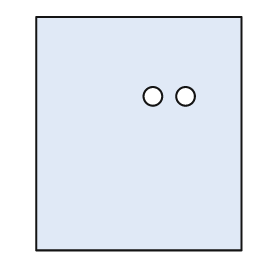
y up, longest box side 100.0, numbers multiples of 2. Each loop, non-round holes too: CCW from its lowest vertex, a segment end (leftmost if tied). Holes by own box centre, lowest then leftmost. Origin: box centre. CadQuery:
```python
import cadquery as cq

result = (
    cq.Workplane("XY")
    .moveTo(-44.0, -50.0)
    .lineTo(44.0, -50.0)
    .lineTo(44.0, 50.0)
    .lineTo(-44.0, 50.0)
    .close()
    .moveTo(6.0, 16.0)
    .circle(4.0)
    .moveTo(20.0, 16.0)
    .circle(4.0)
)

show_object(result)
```